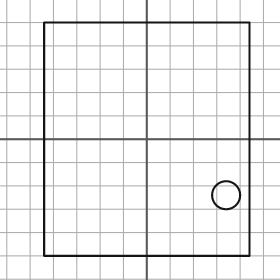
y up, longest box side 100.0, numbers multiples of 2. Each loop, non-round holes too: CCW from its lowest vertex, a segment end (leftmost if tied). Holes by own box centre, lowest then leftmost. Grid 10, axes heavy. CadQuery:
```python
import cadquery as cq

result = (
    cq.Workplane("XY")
    .moveTo(-44.0, -50.0)
    .lineTo(44.0, -50.0)
    .lineTo(44.0, 50.0)
    .lineTo(-44.0, 50.0)
    .close()
    .moveTo(34.0, -24.0)
    .circle(6.0)
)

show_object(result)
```